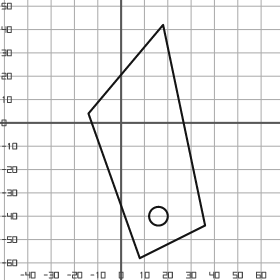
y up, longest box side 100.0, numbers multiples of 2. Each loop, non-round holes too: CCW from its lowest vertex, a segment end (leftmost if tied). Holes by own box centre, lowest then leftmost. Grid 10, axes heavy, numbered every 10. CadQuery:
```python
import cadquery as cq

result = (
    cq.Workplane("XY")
    .moveTo(8.0, -58.0)
    .lineTo(36.0, -44.0)
    .lineTo(18.0, 42.0)
    .lineTo(-14.0, 4.0)
    .close()
    .moveTo(16.0, -40.0)
    .circle(4.0)
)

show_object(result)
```